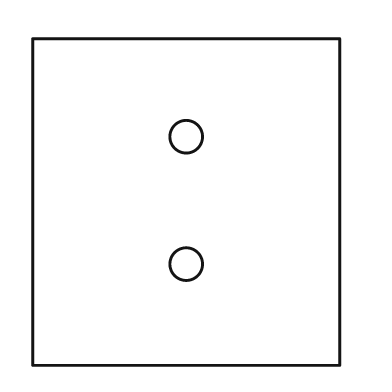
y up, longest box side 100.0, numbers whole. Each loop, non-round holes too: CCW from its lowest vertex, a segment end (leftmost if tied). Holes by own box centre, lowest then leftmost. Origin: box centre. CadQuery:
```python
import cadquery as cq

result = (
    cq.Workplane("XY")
    .moveTo(-47.0, -50.0)
    .lineTo(47.0, -50.0)
    .lineTo(47.0, 50.0)
    .lineTo(-47.0, 50.0)
    .close()
    .moveTo(0.0, -19.0)
    .circle(5.0)
    .moveTo(0.0, 20.0)
    .circle(5.0)
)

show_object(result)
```